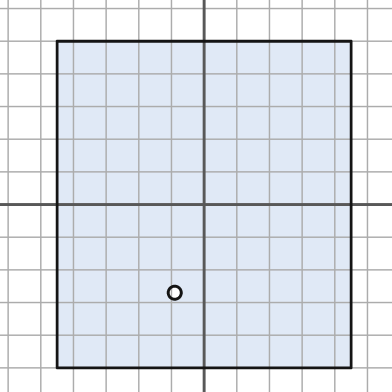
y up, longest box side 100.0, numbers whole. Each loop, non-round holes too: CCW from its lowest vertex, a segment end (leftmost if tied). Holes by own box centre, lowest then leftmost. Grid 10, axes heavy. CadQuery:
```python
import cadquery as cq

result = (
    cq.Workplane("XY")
    .moveTo(-45.0, -50.0)
    .lineTo(45.0, -50.0)
    .lineTo(45.0, 50.0)
    .lineTo(-45.0, 50.0)
    .close()
    .moveTo(-9.0, -27.0)
    .circle(2.0)
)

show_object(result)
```